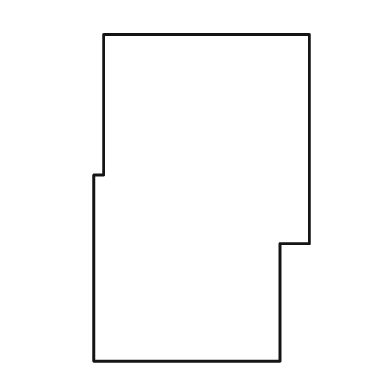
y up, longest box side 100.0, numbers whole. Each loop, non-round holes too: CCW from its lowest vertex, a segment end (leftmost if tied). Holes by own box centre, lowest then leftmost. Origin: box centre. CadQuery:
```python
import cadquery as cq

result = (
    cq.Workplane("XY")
    .moveTo(-33.0, -50.0)
    .lineTo(24.0, -50.0)
    .lineTo(24.0, -14.0)
    .lineTo(33.0, -14.0)
    .lineTo(33.0, 50.0)
    .lineTo(-30.0, 50.0)
    .lineTo(-30.0, 7.0)
    .lineTo(-33.0, 7.0)
    .close()
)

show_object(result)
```